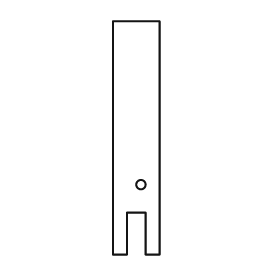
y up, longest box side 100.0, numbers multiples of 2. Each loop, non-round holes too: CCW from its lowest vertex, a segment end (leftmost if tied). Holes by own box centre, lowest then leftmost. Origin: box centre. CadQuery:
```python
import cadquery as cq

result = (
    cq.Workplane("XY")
    .moveTo(-10.0, -50.0)
    .lineTo(-4.0, -50.0)
    .lineTo(-4.0, -32.0)
    .lineTo(4.0, -32.0)
    .lineTo(4.0, -50.0)
    .lineTo(10.0, -50.0)
    .lineTo(10.0, 50.0)
    .lineTo(-10.0, 50.0)
    .close()
    .moveTo(2.0, -20.0)
    .circle(2.0)
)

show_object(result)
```